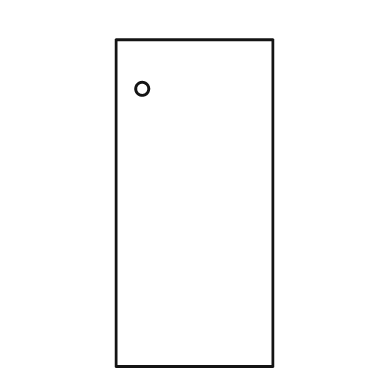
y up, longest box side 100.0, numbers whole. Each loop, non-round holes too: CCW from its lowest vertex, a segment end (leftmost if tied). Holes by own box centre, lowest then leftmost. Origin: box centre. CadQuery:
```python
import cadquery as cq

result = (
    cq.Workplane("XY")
    .moveTo(-24.0, -50.0)
    .lineTo(24.0, -50.0)
    .lineTo(24.0, 50.0)
    .lineTo(-24.0, 50.0)
    .close()
    .moveTo(-16.0, 35.0)
    .circle(2.0)
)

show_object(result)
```